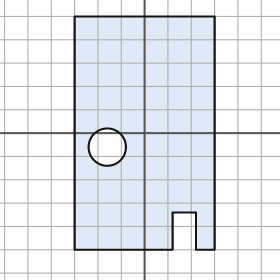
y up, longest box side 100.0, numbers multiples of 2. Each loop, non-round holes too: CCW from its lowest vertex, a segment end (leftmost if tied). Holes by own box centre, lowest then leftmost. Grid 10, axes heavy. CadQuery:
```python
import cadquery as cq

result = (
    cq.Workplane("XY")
    .moveTo(-30.0, -50.0)
    .lineTo(12.0, -50.0)
    .lineTo(12.0, -34.0)
    .lineTo(22.0, -34.0)
    .lineTo(22.0, -50.0)
    .lineTo(30.0, -50.0)
    .lineTo(30.0, 50.0)
    .lineTo(-30.0, 50.0)
    .close()
    .moveTo(-16.0, -6.0)
    .circle(8.0)
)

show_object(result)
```